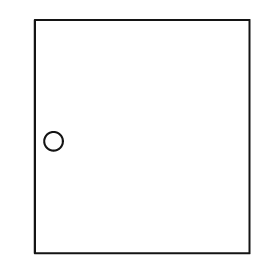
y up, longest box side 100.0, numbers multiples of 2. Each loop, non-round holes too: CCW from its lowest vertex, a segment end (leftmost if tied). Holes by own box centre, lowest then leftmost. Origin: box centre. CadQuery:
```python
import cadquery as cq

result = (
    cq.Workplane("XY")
    .moveTo(-46.0, -50.0)
    .lineTo(46.0, -50.0)
    .lineTo(46.0, 50.0)
    .lineTo(-46.0, 50.0)
    .close()
    .moveTo(-38.0, -2.0)
    .circle(4.0)
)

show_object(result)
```